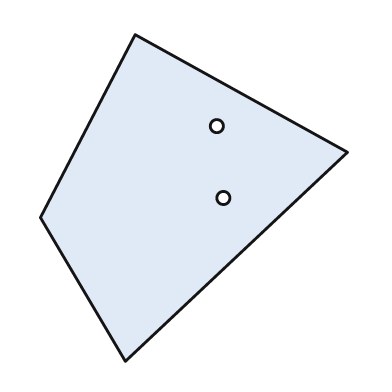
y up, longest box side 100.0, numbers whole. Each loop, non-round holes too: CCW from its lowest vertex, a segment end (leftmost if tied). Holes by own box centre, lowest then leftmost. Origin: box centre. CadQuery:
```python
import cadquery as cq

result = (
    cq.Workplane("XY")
    .moveTo(-21.0, -50.0)
    .lineTo(47.0, 14.0)
    .lineTo(-18.0, 50.0)
    .lineTo(-47.0, -6.0)
    .close()
    .moveTo(9.0, 0.0)
    .circle(2.0)
    .moveTo(7.0, 22.0)
    .circle(2.0)
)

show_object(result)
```